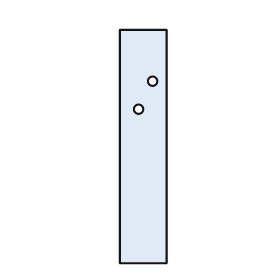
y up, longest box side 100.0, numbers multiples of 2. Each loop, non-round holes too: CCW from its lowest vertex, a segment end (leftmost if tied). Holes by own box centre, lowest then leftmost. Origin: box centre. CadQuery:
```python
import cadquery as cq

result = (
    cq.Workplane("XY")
    .moveTo(-10.0, -50.0)
    .lineTo(10.0, -50.0)
    .lineTo(10.0, 50.0)
    .lineTo(-10.0, 50.0)
    .close()
    .moveTo(-2.0, 16.0)
    .circle(2.0)
    .moveTo(4.0, 28.0)
    .circle(2.0)
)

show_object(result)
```